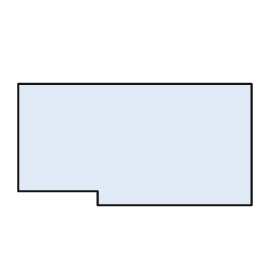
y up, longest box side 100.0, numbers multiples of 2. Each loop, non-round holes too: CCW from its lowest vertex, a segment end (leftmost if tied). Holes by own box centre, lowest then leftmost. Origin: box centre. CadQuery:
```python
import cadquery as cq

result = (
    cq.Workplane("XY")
    .moveTo(-16.0, -26.0)
    .lineTo(50.0, -26.0)
    .lineTo(50.0, 26.0)
    .lineTo(-50.0, 26.0)
    .lineTo(-50.0, -20.0)
    .lineTo(-16.0, -20.0)
    .close()
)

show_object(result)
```